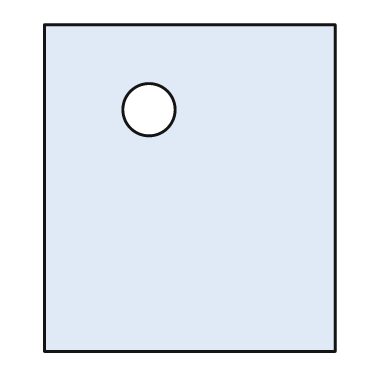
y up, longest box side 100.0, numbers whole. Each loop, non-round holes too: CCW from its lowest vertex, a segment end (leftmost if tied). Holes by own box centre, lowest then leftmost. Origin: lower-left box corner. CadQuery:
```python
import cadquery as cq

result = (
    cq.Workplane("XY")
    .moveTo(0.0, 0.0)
    .lineTo(89.0, 0.0)
    .lineTo(89.0, 100.0)
    .lineTo(0.0, 100.0)
    .close()
    .moveTo(32.0, 74.0)
    .circle(8.0)
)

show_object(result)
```